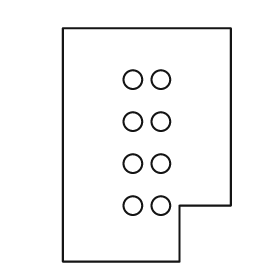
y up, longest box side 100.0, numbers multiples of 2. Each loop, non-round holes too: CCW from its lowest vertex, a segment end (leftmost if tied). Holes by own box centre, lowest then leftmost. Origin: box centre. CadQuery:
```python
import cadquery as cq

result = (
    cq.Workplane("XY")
    .moveTo(-36.0, -50.0)
    .lineTo(14.0, -50.0)
    .lineTo(14.0, -26.0)
    .lineTo(36.0, -26.0)
    .lineTo(36.0, 50.0)
    .lineTo(-36.0, 50.0)
    .close()
    .moveTo(-6.0, -26.0)
    .circle(4.0)
    .moveTo(6.0, -26.0)
    .circle(4.0)
    .moveTo(-6.0, -8.0)
    .circle(4.0)
    .moveTo(6.0, -8.0)
    .circle(4.0)
    .moveTo(-6.0, 10.0)
    .circle(4.0)
    .moveTo(6.0, 10.0)
    .circle(4.0)
    .moveTo(-6.0, 28.0)
    .circle(4.0)
    .moveTo(6.0, 28.0)
    .circle(4.0)
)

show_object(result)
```